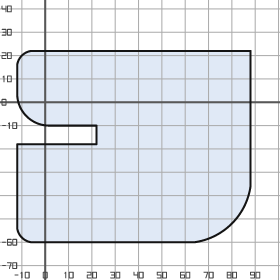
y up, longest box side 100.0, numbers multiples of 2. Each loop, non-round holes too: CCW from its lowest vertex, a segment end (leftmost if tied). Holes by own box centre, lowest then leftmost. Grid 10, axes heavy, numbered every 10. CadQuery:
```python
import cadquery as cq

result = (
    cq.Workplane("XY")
    .moveTo(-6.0, -60.0)
    .lineTo(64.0, -60.0)
    .threePointArc((80.0, -52.0), (88.0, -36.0))
    .lineTo(88.0, 22.0)
    .lineTo(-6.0, 22.0)
    .threePointArc((-10.0, 20.0), (-12.0, 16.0))
    .lineTo(-12.0, 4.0)
    .threePointArc((-8.0, -6.0), (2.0, -10.0))
    .lineTo(22.0, -10.0)
    .lineTo(22.0, -18.0)
    .lineTo(-12.0, -18.0)
    .lineTo(-12.0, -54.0)
    .threePointArc((-10.0, -58.0), (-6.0, -60.0))
    .close()
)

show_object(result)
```